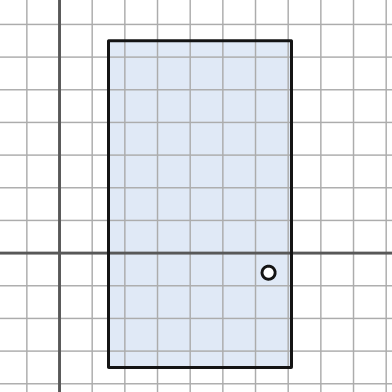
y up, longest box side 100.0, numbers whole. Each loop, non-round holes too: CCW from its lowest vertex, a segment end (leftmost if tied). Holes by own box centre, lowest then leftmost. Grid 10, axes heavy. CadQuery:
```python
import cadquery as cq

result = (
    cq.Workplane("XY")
    .moveTo(15.0, -35.0)
    .lineTo(71.0, -35.0)
    .lineTo(71.0, 65.0)
    .lineTo(15.0, 65.0)
    .close()
    .moveTo(64.0, -6.0)
    .circle(2.0)
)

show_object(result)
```